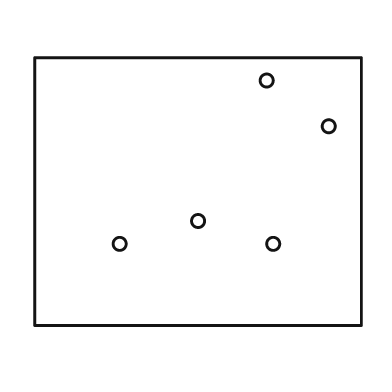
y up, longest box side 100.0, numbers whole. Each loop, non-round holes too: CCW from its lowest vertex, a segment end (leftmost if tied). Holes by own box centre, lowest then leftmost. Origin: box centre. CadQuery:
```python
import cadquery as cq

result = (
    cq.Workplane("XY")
    .moveTo(-50.0, -41.0)
    .lineTo(50.0, -41.0)
    .lineTo(50.0, 41.0)
    .lineTo(-50.0, 41.0)
    .close()
    .moveTo(-24.0, -16.0)
    .circle(2.0)
    .moveTo(23.0, -16.0)
    .circle(2.0)
    .moveTo(0.0, -9.0)
    .circle(2.0)
    .moveTo(40.0, 20.0)
    .circle(2.0)
    .moveTo(21.0, 34.0)
    .circle(2.0)
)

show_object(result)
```